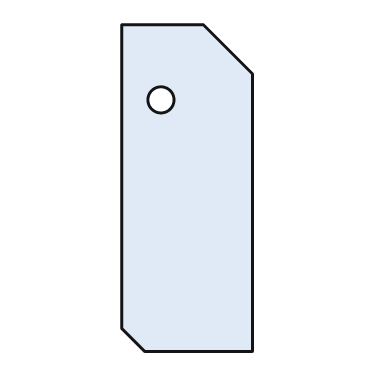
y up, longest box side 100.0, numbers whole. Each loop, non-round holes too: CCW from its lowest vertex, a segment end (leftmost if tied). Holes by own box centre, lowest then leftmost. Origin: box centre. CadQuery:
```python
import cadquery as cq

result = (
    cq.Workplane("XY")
    .moveTo(-13.0, -50.0)
    .lineTo(20.0, -50.0)
    .lineTo(20.0, 35.0)
    .lineTo(5.0, 50.0)
    .lineTo(-20.0, 50.0)
    .lineTo(-20.0, -43.0)
    .close()
    .moveTo(-8.0, 27.0)
    .circle(4.0)
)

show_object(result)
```